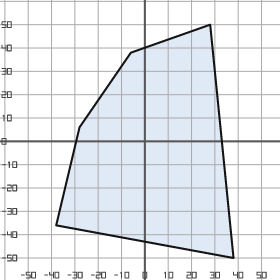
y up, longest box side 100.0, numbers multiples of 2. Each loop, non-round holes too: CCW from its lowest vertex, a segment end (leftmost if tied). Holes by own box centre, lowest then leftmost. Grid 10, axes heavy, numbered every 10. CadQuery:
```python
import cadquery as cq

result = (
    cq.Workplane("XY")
    .moveTo(38.0, -50.0)
    .lineTo(28.0, 50.0)
    .lineTo(-6.0, 38.0)
    .lineTo(-28.0, 6.0)
    .lineTo(-38.0, -36.0)
    .close()
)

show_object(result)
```